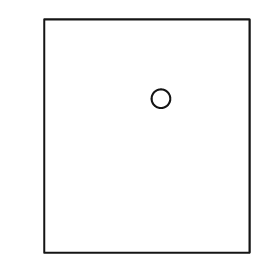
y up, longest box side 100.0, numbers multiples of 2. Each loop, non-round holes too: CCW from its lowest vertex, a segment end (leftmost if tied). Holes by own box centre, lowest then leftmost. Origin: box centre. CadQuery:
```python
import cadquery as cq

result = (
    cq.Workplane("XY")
    .moveTo(-44.0, -50.0)
    .lineTo(44.0, -50.0)
    .lineTo(44.0, 50.0)
    .lineTo(-44.0, 50.0)
    .close()
    .moveTo(6.0, 16.0)
    .circle(4.0)
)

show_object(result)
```